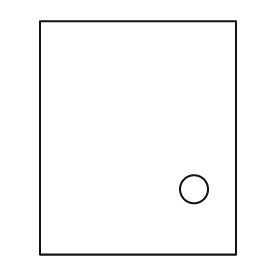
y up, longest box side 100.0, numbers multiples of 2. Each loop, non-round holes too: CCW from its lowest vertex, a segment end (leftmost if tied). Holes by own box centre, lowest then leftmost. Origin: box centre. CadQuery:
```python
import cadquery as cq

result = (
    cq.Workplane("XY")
    .moveTo(-42.0, -50.0)
    .lineTo(42.0, -50.0)
    .lineTo(42.0, 50.0)
    .lineTo(-42.0, 50.0)
    .close()
    .moveTo(24.0, -22.0)
    .circle(6.0)
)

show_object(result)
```